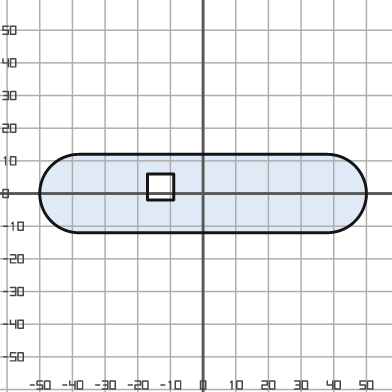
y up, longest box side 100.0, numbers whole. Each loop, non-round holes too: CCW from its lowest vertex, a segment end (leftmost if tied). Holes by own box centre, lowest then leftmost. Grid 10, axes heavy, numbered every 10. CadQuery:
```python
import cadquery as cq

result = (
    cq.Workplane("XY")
    .moveTo(-38.0, -12.0)
    .lineTo(38.0, -12.0)
    .threePointArc((50.0, 0.0), (38.0, 12.0))
    .lineTo(-38.0, 12.0)
    .threePointArc((-50.0, 0.0), (-38.0, -12.0))
    .close()
    .moveTo(-17.0, -2.0)
    .lineTo(-9.0, -2.0)
    .lineTo(-9.0, 6.0)
    .lineTo(-17.0, 6.0)
    .close()
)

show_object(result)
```